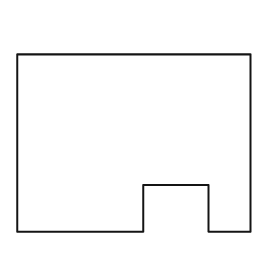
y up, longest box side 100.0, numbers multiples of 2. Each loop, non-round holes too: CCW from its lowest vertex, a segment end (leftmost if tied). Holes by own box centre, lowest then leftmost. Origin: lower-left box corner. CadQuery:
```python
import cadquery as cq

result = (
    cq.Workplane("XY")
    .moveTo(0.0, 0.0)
    .lineTo(54.0, 0.0)
    .lineTo(54.0, 20.0)
    .lineTo(82.0, 20.0)
    .lineTo(82.0, 0.0)
    .lineTo(100.0, 0.0)
    .lineTo(100.0, 76.0)
    .lineTo(0.0, 76.0)
    .close()
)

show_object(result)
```